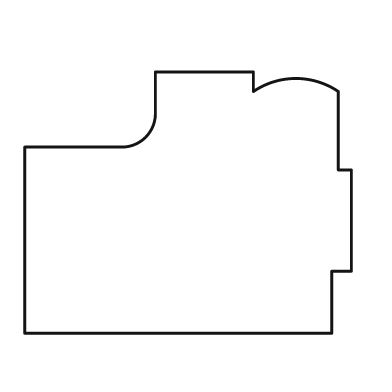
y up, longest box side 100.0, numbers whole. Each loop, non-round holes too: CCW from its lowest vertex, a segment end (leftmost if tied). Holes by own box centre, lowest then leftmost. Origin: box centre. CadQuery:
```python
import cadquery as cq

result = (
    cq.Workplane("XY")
    .moveTo(-50.0, -40.0)
    .lineTo(44.0, -40.0)
    .lineTo(44.0, -21.0)
    .lineTo(50.0, -21.0)
    .lineTo(50.0, 10.0)
    .lineTo(46.0, 10.0)
    .lineTo(46.0, 34.0)
    .threePointArc((33.0, 38.0), (20.0, 34.0))
    .lineTo(20.0, 40.0)
    .lineTo(-10.0, 40.0)
    .lineTo(-10.0, 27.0)
    .threePointArc((-13.0, 20.0), (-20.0, 17.0))
    .lineTo(-50.0, 17.0)
    .close()
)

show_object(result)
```